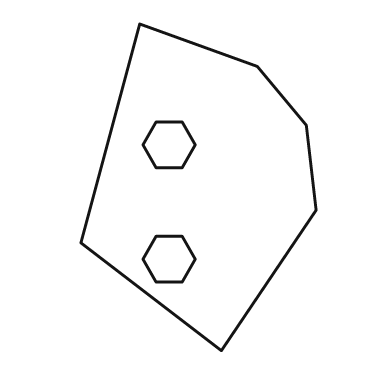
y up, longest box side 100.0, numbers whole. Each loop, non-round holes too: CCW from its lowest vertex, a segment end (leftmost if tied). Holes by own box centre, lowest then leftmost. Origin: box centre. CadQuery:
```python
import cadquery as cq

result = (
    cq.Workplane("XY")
    .moveTo(7.0, -50.0)
    .lineTo(36.0, -7.0)
    .lineTo(33.0, 19.0)
    .lineTo(18.0, 37.0)
    .lineTo(-18.0, 50.0)
    .lineTo(-36.0, -17.0)
    .close()
    .moveTo(-13.0, -29.0)
    .lineTo(-5.0, -29.0)
    .lineTo(-1.0, -22.0)
    .lineTo(-5.0, -15.0)
    .lineTo(-13.0, -15.0)
    .lineTo(-17.0, -22.0)
    .close()
    .moveTo(-13.0, 6.0)
    .lineTo(-5.0, 6.0)
    .lineTo(-1.0, 13.0)
    .lineTo(-5.0, 20.0)
    .lineTo(-13.0, 20.0)
    .lineTo(-17.0, 13.0)
    .close()
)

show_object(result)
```